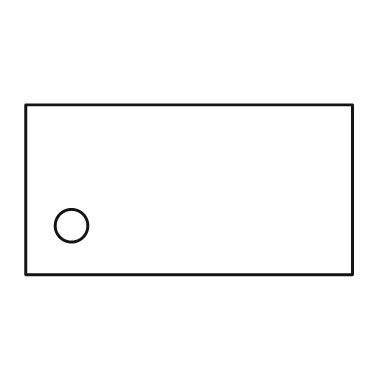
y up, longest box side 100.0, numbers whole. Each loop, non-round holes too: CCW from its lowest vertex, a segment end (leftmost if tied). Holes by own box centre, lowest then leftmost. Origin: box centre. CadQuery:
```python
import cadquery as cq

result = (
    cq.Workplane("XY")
    .moveTo(-50.0, -26.0)
    .lineTo(50.0, -26.0)
    .lineTo(50.0, 26.0)
    .lineTo(-50.0, 26.0)
    .close()
    .moveTo(-36.0, -11.0)
    .circle(5.0)
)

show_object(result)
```